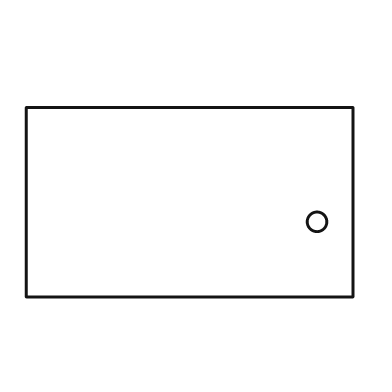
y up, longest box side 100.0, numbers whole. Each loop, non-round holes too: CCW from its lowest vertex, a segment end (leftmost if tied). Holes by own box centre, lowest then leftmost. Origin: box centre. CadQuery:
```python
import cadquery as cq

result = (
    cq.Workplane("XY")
    .moveTo(-50.0, -29.0)
    .lineTo(50.0, -29.0)
    .lineTo(50.0, 29.0)
    .lineTo(-50.0, 29.0)
    .close()
    .moveTo(39.0, -6.0)
    .circle(3.0)
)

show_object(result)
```